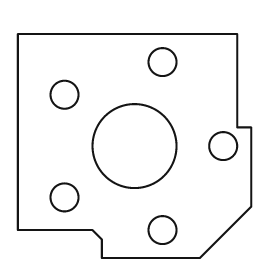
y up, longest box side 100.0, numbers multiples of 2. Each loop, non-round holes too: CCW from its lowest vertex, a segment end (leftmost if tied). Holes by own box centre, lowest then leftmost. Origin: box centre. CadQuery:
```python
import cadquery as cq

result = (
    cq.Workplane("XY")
    .moveTo(-14.0, -48.0)
    .lineTo(28.0, -48.0)
    .lineTo(50.0, -26.0)
    .lineTo(50.0, 8.0)
    .lineTo(44.0, 8.0)
    .lineTo(44.0, 48.0)
    .lineTo(-50.0, 48.0)
    .lineTo(-50.0, -36.0)
    .lineTo(-18.0, -36.0)
    .lineTo(-14.0, -40.0)
    .close()
    .moveTo(12.0, -36.0)
    .circle(6.0)
    .moveTo(-30.0, -22.0)
    .circle(6.0)
    .moveTo(0.0, 0.0)
    .circle(18.0)
    .moveTo(38.0, 0.0)
    .circle(6.0)
    .moveTo(-30.0, 22.0)
    .circle(6.0)
    .moveTo(12.0, 36.0)
    .circle(6.0)
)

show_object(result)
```